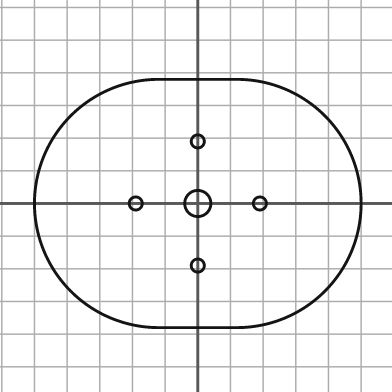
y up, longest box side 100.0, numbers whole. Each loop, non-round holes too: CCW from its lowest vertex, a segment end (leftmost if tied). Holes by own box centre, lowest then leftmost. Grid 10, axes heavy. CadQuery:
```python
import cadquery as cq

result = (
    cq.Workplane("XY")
    .moveTo(-12.0, -38.0)
    .lineTo(12.0, -38.0)
    .threePointArc((50.0, 0.0), (12.0, 38.0))
    .lineTo(-12.0, 38.0)
    .threePointArc((-50.0, 0.0), (-12.0, -38.0))
    .close()
    .moveTo(0.0, -19.0)
    .circle(2.0)
    .moveTo(-19.0, 0.0)
    .circle(2.0)
    .moveTo(0.0, 0.0)
    .circle(4.0)
    .moveTo(19.0, 0.0)
    .circle(2.0)
    .moveTo(0.0, 19.0)
    .circle(2.0)
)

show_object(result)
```